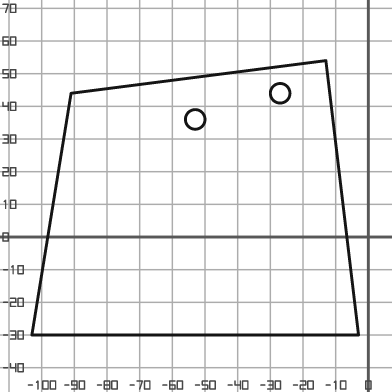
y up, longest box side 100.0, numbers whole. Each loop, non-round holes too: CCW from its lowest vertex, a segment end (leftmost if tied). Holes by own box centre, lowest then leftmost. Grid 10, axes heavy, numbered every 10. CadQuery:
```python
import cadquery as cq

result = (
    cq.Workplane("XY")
    .moveTo(-103.0, -30.0)
    .lineTo(-3.0, -30.0)
    .lineTo(-13.0, 54.0)
    .lineTo(-91.0, 44.0)
    .close()
    .moveTo(-53.0, 36.0)
    .circle(3.0)
    .moveTo(-27.0, 44.0)
    .circle(3.0)
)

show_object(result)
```